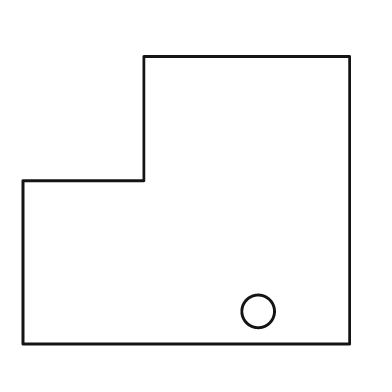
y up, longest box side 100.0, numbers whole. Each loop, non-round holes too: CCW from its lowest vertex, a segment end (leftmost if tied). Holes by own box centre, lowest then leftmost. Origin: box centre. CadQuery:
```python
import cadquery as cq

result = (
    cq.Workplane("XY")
    .moveTo(-50.0, -44.0)
    .lineTo(50.0, -44.0)
    .lineTo(50.0, 44.0)
    .lineTo(-13.0, 44.0)
    .lineTo(-13.0, 6.0)
    .lineTo(-50.0, 6.0)
    .close()
    .moveTo(22.0, -34.0)
    .circle(5.0)
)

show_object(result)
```